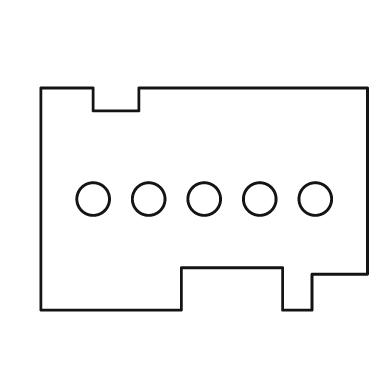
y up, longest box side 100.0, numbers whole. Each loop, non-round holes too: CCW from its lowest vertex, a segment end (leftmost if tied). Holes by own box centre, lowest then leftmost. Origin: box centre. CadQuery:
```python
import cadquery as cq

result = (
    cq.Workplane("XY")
    .moveTo(-50.0, -34.0)
    .lineTo(-7.0, -34.0)
    .lineTo(-7.0, -21.0)
    .lineTo(24.0, -21.0)
    .lineTo(24.0, -34.0)
    .lineTo(33.0, -34.0)
    .lineTo(33.0, -23.0)
    .lineTo(50.0, -23.0)
    .lineTo(50.0, 34.0)
    .lineTo(-20.0, 34.0)
    .lineTo(-20.0, 27.0)
    .lineTo(-34.0, 27.0)
    .lineTo(-34.0, 34.0)
    .lineTo(-50.0, 34.0)
    .close()
    .moveTo(-34.0, 0.0)
    .circle(5.0)
    .moveTo(-17.0, 0.0)
    .circle(5.0)
    .moveTo(0.0, 0.0)
    .circle(5.0)
    .moveTo(17.0, 0.0)
    .circle(5.0)
    .moveTo(34.0, 0.0)
    .circle(5.0)
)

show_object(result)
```